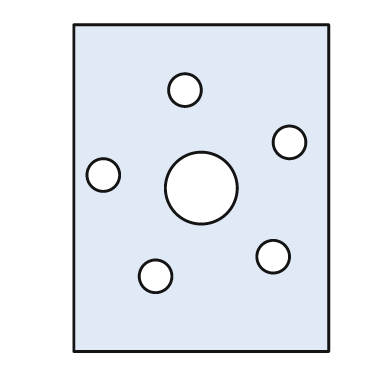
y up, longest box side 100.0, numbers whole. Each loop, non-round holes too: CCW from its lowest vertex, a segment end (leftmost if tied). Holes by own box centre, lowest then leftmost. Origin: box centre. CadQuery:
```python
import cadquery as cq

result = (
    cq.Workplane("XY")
    .moveTo(-39.0, -50.0)
    .lineTo(39.0, -50.0)
    .lineTo(39.0, 50.0)
    .lineTo(-39.0, 50.0)
    .close()
    .moveTo(-14.0, -27.0)
    .circle(5.0)
    .moveTo(22.0, -21.0)
    .circle(5.0)
    .moveTo(0.0, 0.0)
    .circle(11.0)
    .moveTo(-30.0, 4.0)
    .circle(5.0)
    .moveTo(27.0, 14.0)
    .circle(5.0)
    .moveTo(-5.0, 30.0)
    .circle(5.0)
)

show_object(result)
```